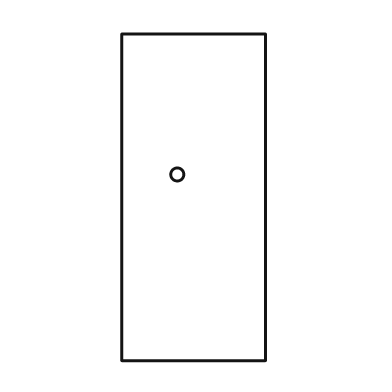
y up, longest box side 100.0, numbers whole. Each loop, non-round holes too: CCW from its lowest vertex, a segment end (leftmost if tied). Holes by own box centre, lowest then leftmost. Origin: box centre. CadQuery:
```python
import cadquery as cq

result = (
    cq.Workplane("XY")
    .moveTo(-22.0, -50.0)
    .lineTo(22.0, -50.0)
    .lineTo(22.0, 50.0)
    .lineTo(-22.0, 50.0)
    .close()
    .moveTo(-5.0, 7.0)
    .circle(2.0)
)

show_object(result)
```